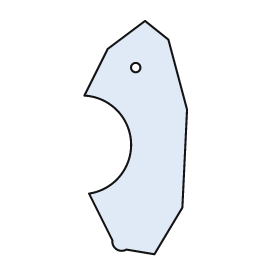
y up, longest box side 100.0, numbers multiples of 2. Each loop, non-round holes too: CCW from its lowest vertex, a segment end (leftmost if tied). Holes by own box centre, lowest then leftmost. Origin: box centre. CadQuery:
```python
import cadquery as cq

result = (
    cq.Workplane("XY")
    .moveTo(8.0, -50.0)
    .lineTo(20.0, -30.0)
    .lineTo(22.0, 12.0)
    .lineTo(14.0, 42.0)
    .lineTo(4.0, 50.0)
    .lineTo(-12.0, 38.0)
    .lineTo(-22.0, 18.0)
    .threePointArc((-2.0, -2.0), (-20.0, -24.0))
    .lineTo(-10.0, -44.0)
    .threePointArc((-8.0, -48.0), (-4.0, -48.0))
    .close()
    .moveTo(0.0, 30.0)
    .circle(2.0)
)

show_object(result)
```